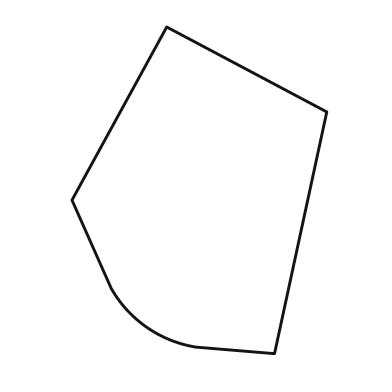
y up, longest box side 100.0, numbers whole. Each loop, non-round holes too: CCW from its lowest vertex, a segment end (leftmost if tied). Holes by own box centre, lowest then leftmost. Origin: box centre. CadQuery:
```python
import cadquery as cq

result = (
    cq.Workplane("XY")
    .moveTo(23.0, -50.0)
    .lineTo(39.0, 24.0)
    .lineTo(-10.0, 50.0)
    .lineTo(-39.0, -3.0)
    .lineTo(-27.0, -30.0)
    .threePointArc((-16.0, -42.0), (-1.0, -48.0))
    .close()
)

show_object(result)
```